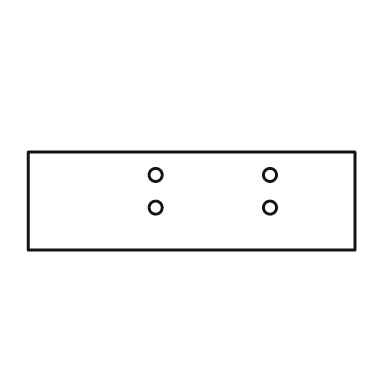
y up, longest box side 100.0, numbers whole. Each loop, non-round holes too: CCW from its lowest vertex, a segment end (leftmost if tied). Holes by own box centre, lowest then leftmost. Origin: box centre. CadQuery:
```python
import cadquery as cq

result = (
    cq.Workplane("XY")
    .moveTo(-50.0, -15.0)
    .lineTo(50.0, -15.0)
    .lineTo(50.0, 15.0)
    .lineTo(-50.0, 15.0)
    .close()
    .moveTo(-11.0, -2.0)
    .circle(2.0)
    .moveTo(24.0, -2.0)
    .circle(2.0)
    .moveTo(-11.0, 8.0)
    .circle(2.0)
    .moveTo(24.0, 8.0)
    .circle(2.0)
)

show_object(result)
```